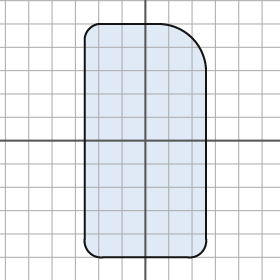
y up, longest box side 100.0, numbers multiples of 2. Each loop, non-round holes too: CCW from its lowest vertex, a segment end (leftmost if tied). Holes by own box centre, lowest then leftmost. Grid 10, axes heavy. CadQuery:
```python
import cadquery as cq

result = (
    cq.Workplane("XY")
    .moveTo(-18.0, -50.0)
    .lineTo(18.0, -50.0)
    .threePointArc((24.0, -48.0), (26.0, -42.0))
    .lineTo(26.0, 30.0)
    .threePointArc((20.0, 44.0), (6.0, 50.0))
    .lineTo(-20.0, 50.0)
    .threePointArc((-24.0, 48.0), (-26.0, 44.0))
    .lineTo(-26.0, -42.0)
    .threePointArc((-24.0, -48.0), (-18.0, -50.0))
    .close()
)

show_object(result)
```